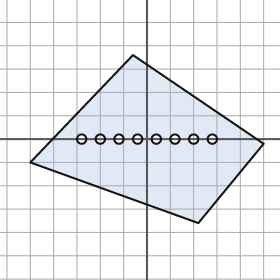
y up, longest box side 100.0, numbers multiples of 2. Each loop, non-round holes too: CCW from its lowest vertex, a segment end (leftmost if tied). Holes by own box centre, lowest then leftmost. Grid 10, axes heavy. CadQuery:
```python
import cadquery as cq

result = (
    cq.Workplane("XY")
    .moveTo(22.0, -36.0)
    .lineTo(50.0, -2.0)
    .lineTo(-6.0, 36.0)
    .lineTo(-50.0, -10.0)
    .close()
    .moveTo(-28.0, 0.0)
    .circle(2.0)
    .moveTo(-20.0, 0.0)
    .circle(2.0)
    .moveTo(-12.0, 0.0)
    .circle(2.0)
    .moveTo(-4.0, 0.0)
    .circle(2.0)
    .moveTo(4.0, 0.0)
    .circle(2.0)
    .moveTo(12.0, 0.0)
    .circle(2.0)
    .moveTo(20.0, 0.0)
    .circle(2.0)
    .moveTo(28.0, 0.0)
    .circle(2.0)
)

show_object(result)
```